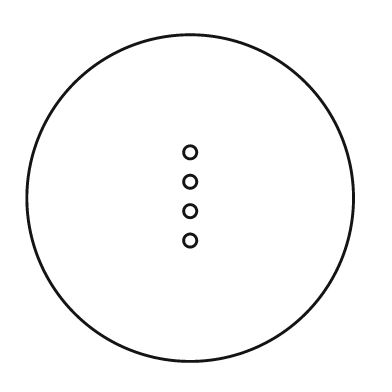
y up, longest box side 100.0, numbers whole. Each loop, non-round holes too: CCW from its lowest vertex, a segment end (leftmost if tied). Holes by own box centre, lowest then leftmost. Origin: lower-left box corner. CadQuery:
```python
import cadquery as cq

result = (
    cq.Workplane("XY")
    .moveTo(50.0, 50.0)
    .circle(50.0)
    .moveTo(50.0, 37.0)
    .circle(2.0)
    .moveTo(50.0, 46.0)
    .circle(2.0)
    .moveTo(50.0, 55.0)
    .circle(2.0)
    .moveTo(50.0, 64.0)
    .circle(2.0)
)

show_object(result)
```